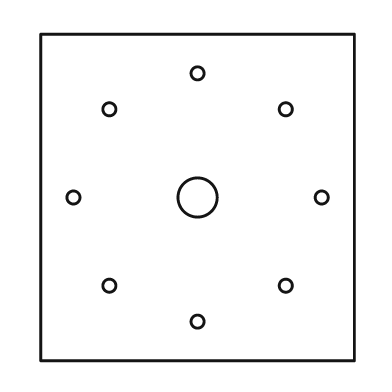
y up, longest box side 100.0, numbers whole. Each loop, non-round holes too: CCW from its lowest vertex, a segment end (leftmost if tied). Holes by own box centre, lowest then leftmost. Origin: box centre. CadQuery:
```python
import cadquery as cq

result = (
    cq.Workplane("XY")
    .moveTo(-48.0, -50.0)
    .lineTo(48.0, -50.0)
    .lineTo(48.0, 50.0)
    .lineTo(-48.0, 50.0)
    .close()
    .moveTo(0.0, -38.0)
    .circle(2.0)
    .moveTo(-27.0, -27.0)
    .circle(2.0)
    .moveTo(27.0, -27.0)
    .circle(2.0)
    .moveTo(-38.0, 0.0)
    .circle(2.0)
    .moveTo(0.0, 0.0)
    .circle(6.0)
    .moveTo(38.0, 0.0)
    .circle(2.0)
    .moveTo(-27.0, 27.0)
    .circle(2.0)
    .moveTo(27.0, 27.0)
    .circle(2.0)
    .moveTo(0.0, 38.0)
    .circle(2.0)
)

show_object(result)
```